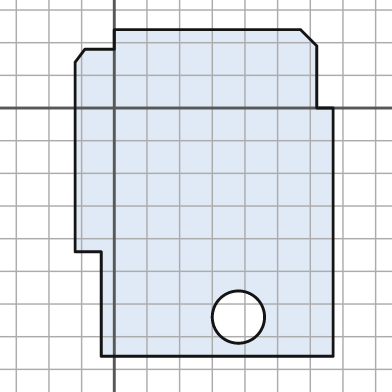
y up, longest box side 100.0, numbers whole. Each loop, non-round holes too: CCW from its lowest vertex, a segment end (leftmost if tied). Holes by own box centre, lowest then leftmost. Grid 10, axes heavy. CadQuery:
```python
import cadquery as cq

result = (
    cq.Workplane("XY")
    .moveTo(-4.0, -76.0)
    .lineTo(67.0, -76.0)
    .lineTo(67.0, 0.0)
    .lineTo(62.0, 0.0)
    .lineTo(62.0, 19.0)
    .lineTo(57.0, 24.0)
    .lineTo(0.0, 24.0)
    .lineTo(0.0, 18.0)
    .lineTo(-9.0, 18.0)
    .lineTo(-12.0, 14.0)
    .lineTo(-12.0, -44.0)
    .lineTo(-4.0, -44.0)
    .close()
    .moveTo(38.0, -64.0)
    .circle(8.0)
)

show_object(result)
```